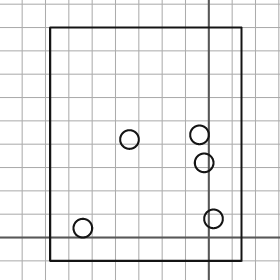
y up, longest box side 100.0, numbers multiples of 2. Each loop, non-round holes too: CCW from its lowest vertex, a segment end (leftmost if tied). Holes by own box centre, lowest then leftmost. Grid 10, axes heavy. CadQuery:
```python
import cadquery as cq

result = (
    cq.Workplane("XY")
    .moveTo(-68.0, -10.0)
    .lineTo(14.0, -10.0)
    .lineTo(14.0, 90.0)
    .lineTo(-68.0, 90.0)
    .close()
    .moveTo(-54.0, 4.0)
    .circle(4.0)
    .moveTo(2.0, 8.0)
    .circle(4.0)
    .moveTo(-2.0, 32.0)
    .circle(4.0)
    .moveTo(-34.0, 42.0)
    .circle(4.0)
    .moveTo(-4.0, 44.0)
    .circle(4.0)
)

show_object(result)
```